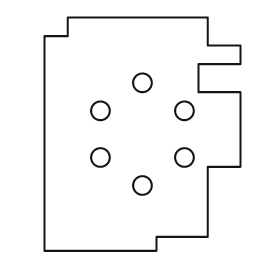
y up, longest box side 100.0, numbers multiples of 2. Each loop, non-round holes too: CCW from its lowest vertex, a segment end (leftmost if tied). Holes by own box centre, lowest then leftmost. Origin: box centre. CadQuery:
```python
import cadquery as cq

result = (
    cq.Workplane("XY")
    .moveTo(-42.0, -50.0)
    .lineTo(6.0, -50.0)
    .lineTo(6.0, -44.0)
    .lineTo(28.0, -44.0)
    .lineTo(28.0, -14.0)
    .lineTo(42.0, -14.0)
    .lineTo(42.0, 18.0)
    .lineTo(24.0, 18.0)
    .lineTo(24.0, 30.0)
    .lineTo(42.0, 30.0)
    .lineTo(42.0, 38.0)
    .lineTo(28.0, 38.0)
    .lineTo(28.0, 50.0)
    .lineTo(-32.0, 50.0)
    .lineTo(-32.0, 42.0)
    .lineTo(-42.0, 42.0)
    .close()
    .moveTo(0.0, -22.0)
    .circle(4.0)
    .moveTo(-18.0, -10.0)
    .circle(4.0)
    .moveTo(18.0, -10.0)
    .circle(4.0)
    .moveTo(-18.0, 10.0)
    .circle(4.0)
    .moveTo(18.0, 10.0)
    .circle(4.0)
    .moveTo(0.0, 22.0)
    .circle(4.0)
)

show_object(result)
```